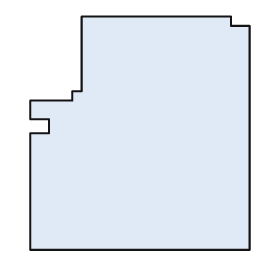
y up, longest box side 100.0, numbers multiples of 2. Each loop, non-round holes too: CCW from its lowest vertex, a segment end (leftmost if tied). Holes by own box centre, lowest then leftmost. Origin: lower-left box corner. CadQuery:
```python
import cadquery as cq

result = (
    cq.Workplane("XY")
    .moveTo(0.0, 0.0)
    .lineTo(94.0, 0.0)
    .lineTo(94.0, 96.0)
    .lineTo(86.0, 96.0)
    .lineTo(86.0, 100.0)
    .lineTo(22.0, 100.0)
    .lineTo(22.0, 68.0)
    .lineTo(18.0, 68.0)
    .lineTo(18.0, 64.0)
    .lineTo(0.0, 64.0)
    .lineTo(0.0, 56.0)
    .lineTo(8.0, 56.0)
    .lineTo(8.0, 50.0)
    .lineTo(0.0, 50.0)
    .close()
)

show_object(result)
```